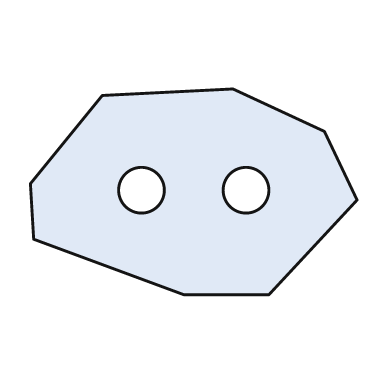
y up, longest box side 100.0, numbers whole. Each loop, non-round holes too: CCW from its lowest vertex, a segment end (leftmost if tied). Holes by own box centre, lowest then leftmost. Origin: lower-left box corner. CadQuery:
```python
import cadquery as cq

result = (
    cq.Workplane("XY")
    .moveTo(47.0, 0.0)
    .lineTo(73.0, 0.0)
    .lineTo(100.0, 29.0)
    .lineTo(90.0, 50.0)
    .lineTo(62.0, 63.0)
    .lineTo(22.0, 61.0)
    .lineTo(0.0, 34.0)
    .lineTo(1.0, 17.0)
    .close()
    .moveTo(34.0, 32.0)
    .circle(7.0)
    .moveTo(66.0, 32.0)
    .circle(7.0)
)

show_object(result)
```